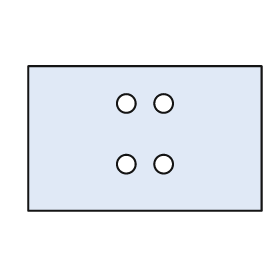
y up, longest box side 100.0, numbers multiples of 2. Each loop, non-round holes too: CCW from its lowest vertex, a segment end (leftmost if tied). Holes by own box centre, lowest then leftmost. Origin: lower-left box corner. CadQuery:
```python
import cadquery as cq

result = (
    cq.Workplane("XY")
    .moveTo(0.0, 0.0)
    .lineTo(100.0, 0.0)
    .lineTo(100.0, 62.0)
    .lineTo(0.0, 62.0)
    .close()
    .moveTo(42.0, 20.0)
    .circle(4.0)
    .moveTo(58.0, 20.0)
    .circle(4.0)
    .moveTo(42.0, 46.0)
    .circle(4.0)
    .moveTo(58.0, 46.0)
    .circle(4.0)
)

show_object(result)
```